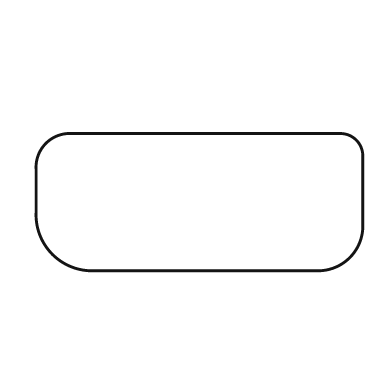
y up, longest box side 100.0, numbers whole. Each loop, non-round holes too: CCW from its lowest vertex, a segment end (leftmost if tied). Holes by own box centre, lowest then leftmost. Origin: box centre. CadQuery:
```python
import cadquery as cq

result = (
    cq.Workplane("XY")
    .moveTo(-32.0, -21.0)
    .lineTo(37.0, -21.0)
    .threePointArc((46.0, -17.0), (50.0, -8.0))
    .lineTo(50.0, 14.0)
    .threePointArc((48.0, 19.0), (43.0, 21.0))
    .lineTo(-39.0, 21.0)
    .threePointArc((-47.0, 18.0), (-50.0, 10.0))
    .lineTo(-50.0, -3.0)
    .threePointArc((-45.0, -16.0), (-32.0, -21.0))
    .close()
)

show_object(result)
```